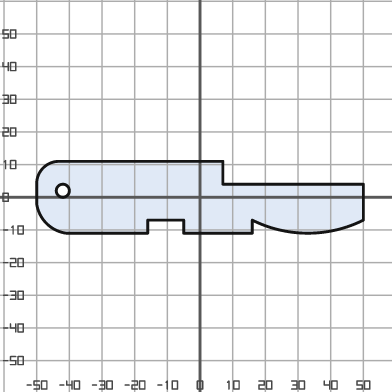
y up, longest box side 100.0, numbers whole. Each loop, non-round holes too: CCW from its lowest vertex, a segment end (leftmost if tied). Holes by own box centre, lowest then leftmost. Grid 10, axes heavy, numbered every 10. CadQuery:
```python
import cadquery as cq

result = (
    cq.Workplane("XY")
    .moveTo(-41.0, -11.0)
    .lineTo(-16.0, -11.0)
    .lineTo(-16.0, -7.0)
    .lineTo(-5.0, -7.0)
    .lineTo(-5.0, -11.0)
    .lineTo(16.0, -11.0)
    .lineTo(16.0, -7.0)
    .threePointArc((33.0, -11.0), (50.0, -7.0))
    .lineTo(50.0, 4.0)
    .lineTo(7.0, 4.0)
    .lineTo(7.0, 11.0)
    .lineTo(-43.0, 11.0)
    .threePointArc((-48.0, 9.0), (-50.0, 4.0))
    .lineTo(-50.0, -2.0)
    .threePointArc((-47.0, -8.0), (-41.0, -11.0))
    .close()
    .moveTo(-42.0, 2.0)
    .circle(2.0)
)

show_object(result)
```